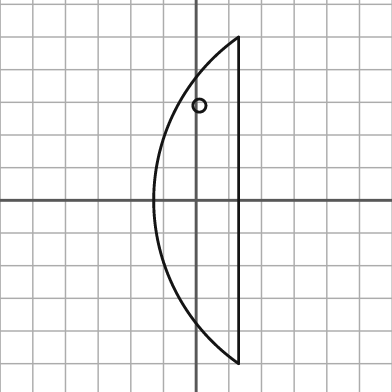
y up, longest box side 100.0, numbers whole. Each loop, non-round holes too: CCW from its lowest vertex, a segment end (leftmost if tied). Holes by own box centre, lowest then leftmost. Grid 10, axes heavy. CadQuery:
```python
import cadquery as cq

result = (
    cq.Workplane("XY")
    .moveTo(13.0, -50.0)
    .lineTo(13.0, 50.0)
    .threePointArc((-13.0, 0.0), (13.0, -50.0))
    .close()
    .moveTo(1.0, 29.0)
    .circle(2.0)
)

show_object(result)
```